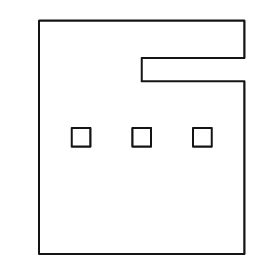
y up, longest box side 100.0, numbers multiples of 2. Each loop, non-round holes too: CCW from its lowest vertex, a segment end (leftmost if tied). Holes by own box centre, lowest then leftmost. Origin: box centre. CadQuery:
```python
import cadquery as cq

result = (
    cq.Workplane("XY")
    .moveTo(-44.0, -50.0)
    .lineTo(44.0, -50.0)
    .lineTo(44.0, 24.0)
    .lineTo(0.0, 24.0)
    .lineTo(0.0, 34.0)
    .lineTo(44.0, 34.0)
    .lineTo(44.0, 50.0)
    .lineTo(-44.0, 50.0)
    .close()
    .moveTo(-30.0, -4.0)
    .lineTo(-22.0, -4.0)
    .lineTo(-22.0, 4.0)
    .lineTo(-30.0, 4.0)
    .close()
    .moveTo(-4.0, -4.0)
    .lineTo(4.0, -4.0)
    .lineTo(4.0, 4.0)
    .lineTo(-4.0, 4.0)
    .close()
    .moveTo(22.0, -4.0)
    .lineTo(30.0, -4.0)
    .lineTo(30.0, 4.0)
    .lineTo(22.0, 4.0)
    .close()
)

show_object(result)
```